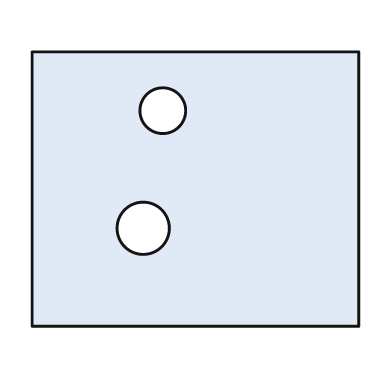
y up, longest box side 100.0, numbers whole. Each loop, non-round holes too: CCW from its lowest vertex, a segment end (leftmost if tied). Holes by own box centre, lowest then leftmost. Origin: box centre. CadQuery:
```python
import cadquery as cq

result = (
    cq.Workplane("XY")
    .moveTo(-50.0, -42.0)
    .lineTo(50.0, -42.0)
    .lineTo(50.0, 42.0)
    .lineTo(-50.0, 42.0)
    .close()
    .moveTo(-16.0, -12.0)
    .circle(8.0)
    .moveTo(-10.0, 24.0)
    .circle(7.0)
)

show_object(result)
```